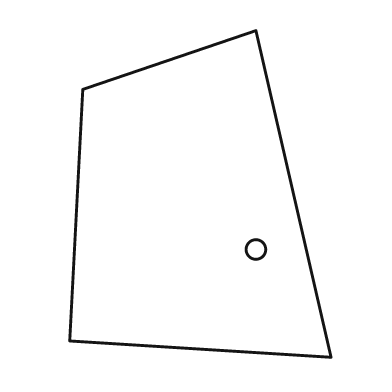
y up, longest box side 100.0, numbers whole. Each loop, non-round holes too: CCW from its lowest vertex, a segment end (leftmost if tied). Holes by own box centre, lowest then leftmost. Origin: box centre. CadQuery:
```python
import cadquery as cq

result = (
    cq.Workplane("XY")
    .moveTo(40.0, -50.0)
    .lineTo(17.0, 50.0)
    .lineTo(-36.0, 32.0)
    .lineTo(-40.0, -45.0)
    .close()
    .moveTo(17.0, -17.0)
    .circle(3.0)
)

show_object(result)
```